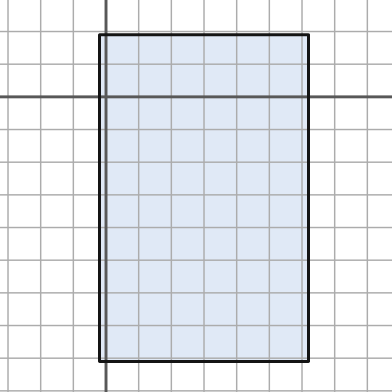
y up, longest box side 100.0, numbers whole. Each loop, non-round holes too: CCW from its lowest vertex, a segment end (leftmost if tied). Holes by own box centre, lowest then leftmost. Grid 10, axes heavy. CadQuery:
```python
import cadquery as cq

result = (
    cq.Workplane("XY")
    .moveTo(-2.0, -81.0)
    .lineTo(62.0, -81.0)
    .lineTo(62.0, 19.0)
    .lineTo(-2.0, 19.0)
    .close()
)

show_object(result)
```